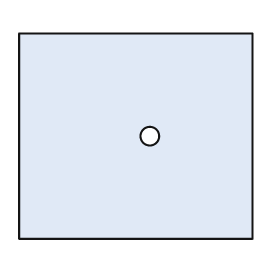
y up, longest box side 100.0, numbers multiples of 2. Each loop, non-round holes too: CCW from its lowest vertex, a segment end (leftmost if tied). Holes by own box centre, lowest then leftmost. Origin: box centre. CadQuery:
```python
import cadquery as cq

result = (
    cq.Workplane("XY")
    .moveTo(-50.0, -44.0)
    .lineTo(50.0, -44.0)
    .lineTo(50.0, 44.0)
    .lineTo(-50.0, 44.0)
    .close()
    .moveTo(6.0, 0.0)
    .circle(4.0)
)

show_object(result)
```